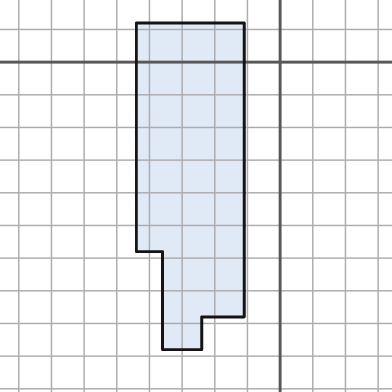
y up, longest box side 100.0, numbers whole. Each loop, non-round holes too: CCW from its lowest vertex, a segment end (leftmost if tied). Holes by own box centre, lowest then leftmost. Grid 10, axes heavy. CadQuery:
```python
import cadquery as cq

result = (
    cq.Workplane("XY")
    .moveTo(-36.0, -88.0)
    .lineTo(-24.0, -88.0)
    .lineTo(-24.0, -78.0)
    .lineTo(-11.0, -78.0)
    .lineTo(-11.0, 12.0)
    .lineTo(-44.0, 12.0)
    .lineTo(-44.0, -58.0)
    .lineTo(-36.0, -58.0)
    .close()
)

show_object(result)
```